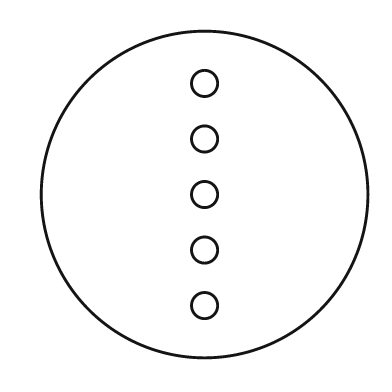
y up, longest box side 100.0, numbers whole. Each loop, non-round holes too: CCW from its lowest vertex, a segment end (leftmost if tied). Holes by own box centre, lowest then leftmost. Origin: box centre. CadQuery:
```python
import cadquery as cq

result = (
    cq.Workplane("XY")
    .moveTo(0.0, 0.0)
    .circle(50.0)
    .moveTo(0.0, -34.0)
    .circle(4.0)
    .moveTo(0.0, -17.0)
    .circle(4.0)
    .moveTo(0.0, 0.0)
    .circle(4.0)
    .moveTo(0.0, 17.0)
    .circle(4.0)
    .moveTo(0.0, 34.0)
    .circle(4.0)
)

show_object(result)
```